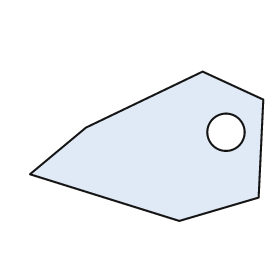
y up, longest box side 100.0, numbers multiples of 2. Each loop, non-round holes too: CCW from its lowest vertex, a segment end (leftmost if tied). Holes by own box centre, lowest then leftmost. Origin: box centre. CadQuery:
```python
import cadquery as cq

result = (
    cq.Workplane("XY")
    .moveTo(14.0, -32.0)
    .lineTo(48.0, -22.0)
    .lineTo(50.0, 20.0)
    .lineTo(24.0, 32.0)
    .lineTo(-26.0, 8.0)
    .lineTo(-50.0, -12.0)
    .close()
    .moveTo(34.0, 6.0)
    .circle(8.0)
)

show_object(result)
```